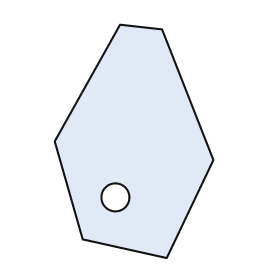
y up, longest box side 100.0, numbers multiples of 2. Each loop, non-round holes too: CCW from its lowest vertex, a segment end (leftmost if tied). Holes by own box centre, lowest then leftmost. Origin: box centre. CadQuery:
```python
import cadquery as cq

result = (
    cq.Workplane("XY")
    .moveTo(14.0, -50.0)
    .lineTo(34.0, -8.0)
    .lineTo(12.0, 48.0)
    .lineTo(-6.0, 50.0)
    .lineTo(-34.0, 0.0)
    .lineTo(-22.0, -42.0)
    .close()
    .moveTo(-8.0, -24.0)
    .circle(6.0)
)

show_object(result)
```